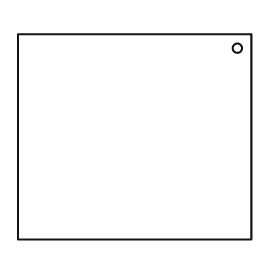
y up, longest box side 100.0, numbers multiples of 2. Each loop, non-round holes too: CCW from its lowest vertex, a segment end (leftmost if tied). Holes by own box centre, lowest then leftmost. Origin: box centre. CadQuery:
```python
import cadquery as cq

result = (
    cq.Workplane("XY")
    .moveTo(-50.0, -44.0)
    .lineTo(50.0, -44.0)
    .lineTo(50.0, 44.0)
    .lineTo(-50.0, 44.0)
    .close()
    .moveTo(44.0, 38.0)
    .circle(2.0)
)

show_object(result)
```